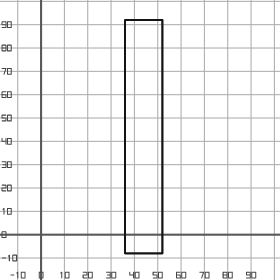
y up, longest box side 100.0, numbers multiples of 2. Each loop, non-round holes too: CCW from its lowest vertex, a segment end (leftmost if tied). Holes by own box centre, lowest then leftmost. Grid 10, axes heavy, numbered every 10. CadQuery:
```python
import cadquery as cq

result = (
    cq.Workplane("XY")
    .moveTo(36.0, -8.0)
    .lineTo(52.0, -8.0)
    .lineTo(52.0, 92.0)
    .lineTo(36.0, 92.0)
    .close()
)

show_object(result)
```